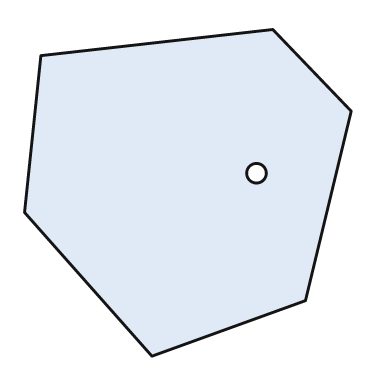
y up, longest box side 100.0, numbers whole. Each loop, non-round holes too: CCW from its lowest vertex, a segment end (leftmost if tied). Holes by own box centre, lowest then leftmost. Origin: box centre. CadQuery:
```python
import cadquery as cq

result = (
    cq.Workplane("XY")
    .moveTo(-11.0, -50.0)
    .lineTo(36.0, -33.0)
    .lineTo(50.0, 25.0)
    .lineTo(26.0, 50.0)
    .lineTo(-45.0, 42.0)
    .lineTo(-50.0, -6.0)
    .close()
    .moveTo(21.0, 6.0)
    .circle(3.0)
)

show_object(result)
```